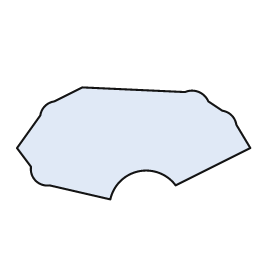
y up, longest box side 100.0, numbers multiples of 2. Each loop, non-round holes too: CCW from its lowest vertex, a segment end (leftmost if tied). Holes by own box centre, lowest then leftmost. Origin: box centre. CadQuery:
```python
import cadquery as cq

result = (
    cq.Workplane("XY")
    .moveTo(-10.0, -24.0)
    .threePointArc((2.0, -12.0), (18.0, -18.0))
    .lineTo(50.0, -2.0)
    .lineTo(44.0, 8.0)
    .threePointArc((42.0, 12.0), (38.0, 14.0))
    .lineTo(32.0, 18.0)
    .threePointArc((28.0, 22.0), (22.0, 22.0))
    .lineTo(-22.0, 24.0)
    .lineTo(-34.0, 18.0)
    .threePointArc((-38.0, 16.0), (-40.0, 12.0))
    .lineTo(-50.0, -2.0)
    .lineTo(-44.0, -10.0)
    .threePointArc((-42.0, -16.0), (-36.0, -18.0))
    .close()
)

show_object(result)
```